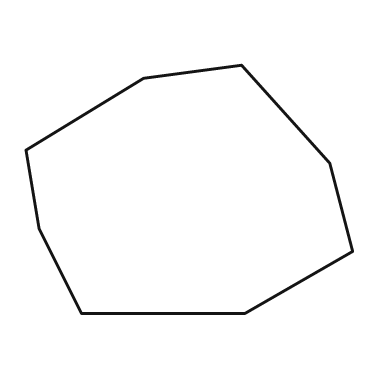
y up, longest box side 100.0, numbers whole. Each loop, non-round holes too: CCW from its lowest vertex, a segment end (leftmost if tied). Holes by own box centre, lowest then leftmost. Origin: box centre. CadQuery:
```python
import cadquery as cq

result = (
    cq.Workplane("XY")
    .moveTo(-33.0, -38.0)
    .lineTo(17.0, -38.0)
    .lineTo(50.0, -19.0)
    .lineTo(43.0, 8.0)
    .lineTo(16.0, 38.0)
    .lineTo(-14.0, 34.0)
    .lineTo(-50.0, 12.0)
    .lineTo(-46.0, -12.0)
    .close()
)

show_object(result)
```